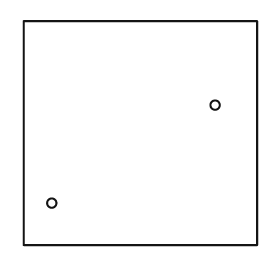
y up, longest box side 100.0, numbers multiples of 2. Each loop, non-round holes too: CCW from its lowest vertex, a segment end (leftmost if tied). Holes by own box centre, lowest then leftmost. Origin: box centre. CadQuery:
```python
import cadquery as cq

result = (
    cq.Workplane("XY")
    .moveTo(-50.0, -48.0)
    .lineTo(50.0, -48.0)
    .lineTo(50.0, 48.0)
    .lineTo(-50.0, 48.0)
    .close()
    .moveTo(-38.0, -30.0)
    .circle(2.0)
    .moveTo(32.0, 12.0)
    .circle(2.0)
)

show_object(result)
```